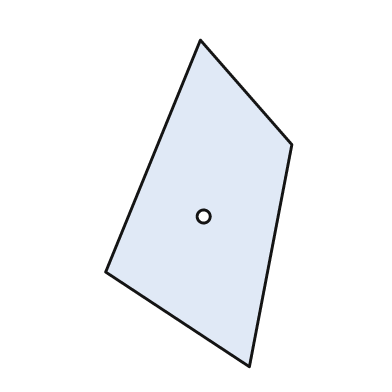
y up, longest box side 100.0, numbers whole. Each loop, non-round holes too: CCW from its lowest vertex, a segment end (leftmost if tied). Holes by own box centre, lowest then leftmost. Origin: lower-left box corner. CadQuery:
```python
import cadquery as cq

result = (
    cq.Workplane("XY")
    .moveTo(44.0, 0.0)
    .lineTo(57.0, 68.0)
    .lineTo(29.0, 100.0)
    .lineTo(0.0, 29.0)
    .close()
    .moveTo(30.0, 46.0)
    .circle(2.0)
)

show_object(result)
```